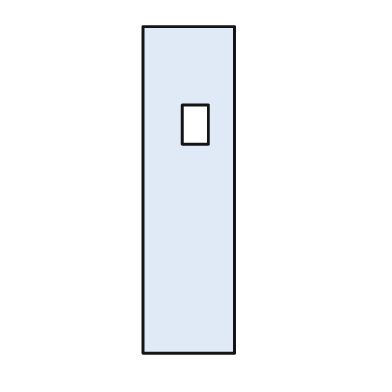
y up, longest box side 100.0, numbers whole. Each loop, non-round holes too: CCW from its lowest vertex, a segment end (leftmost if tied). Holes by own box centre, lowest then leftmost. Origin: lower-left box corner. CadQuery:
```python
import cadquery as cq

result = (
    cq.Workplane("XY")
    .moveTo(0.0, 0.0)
    .lineTo(28.0, 0.0)
    .lineTo(28.0, 100.0)
    .lineTo(0.0, 100.0)
    .close()
    .moveTo(12.0, 64.0)
    .lineTo(20.0, 64.0)
    .lineTo(20.0, 76.0)
    .lineTo(12.0, 76.0)
    .close()
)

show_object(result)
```